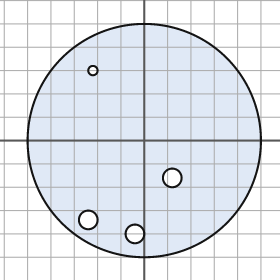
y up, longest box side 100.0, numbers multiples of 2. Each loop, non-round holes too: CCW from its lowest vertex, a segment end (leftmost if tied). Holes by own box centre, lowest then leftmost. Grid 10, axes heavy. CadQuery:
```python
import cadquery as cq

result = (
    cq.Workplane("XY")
    .moveTo(0.0, 0.0)
    .circle(50.0)
    .moveTo(-4.0, -40.0)
    .circle(4.0)
    .moveTo(-24.0, -34.0)
    .circle(4.0)
    .moveTo(12.0, -16.0)
    .circle(4.0)
    .moveTo(-22.0, 30.0)
    .circle(2.0)
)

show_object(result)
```